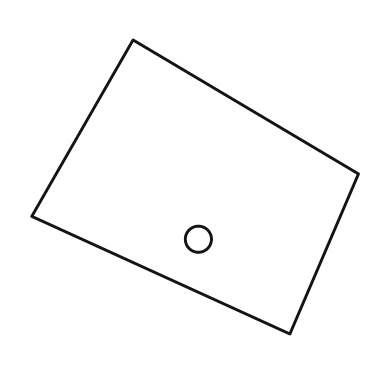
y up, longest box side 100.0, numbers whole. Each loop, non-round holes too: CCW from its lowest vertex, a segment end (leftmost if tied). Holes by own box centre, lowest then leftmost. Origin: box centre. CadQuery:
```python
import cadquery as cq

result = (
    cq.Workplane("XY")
    .moveTo(29.0, -45.0)
    .lineTo(50.0, 4.0)
    .lineTo(-19.0, 45.0)
    .lineTo(-50.0, -9.0)
    .close()
    .moveTo(1.0, -16.0)
    .circle(4.0)
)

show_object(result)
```